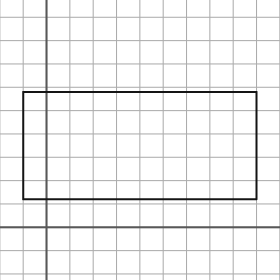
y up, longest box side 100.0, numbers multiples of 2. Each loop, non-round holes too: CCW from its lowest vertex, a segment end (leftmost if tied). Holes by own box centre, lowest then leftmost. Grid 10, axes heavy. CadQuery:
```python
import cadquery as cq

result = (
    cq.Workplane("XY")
    .moveTo(-10.0, 12.0)
    .lineTo(90.0, 12.0)
    .lineTo(90.0, 58.0)
    .lineTo(-10.0, 58.0)
    .close()
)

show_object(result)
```